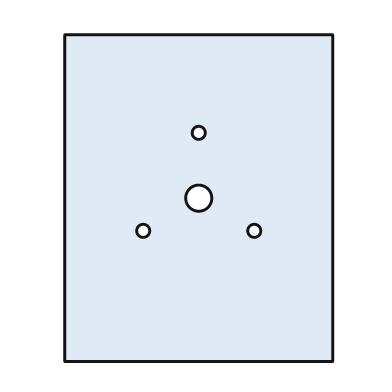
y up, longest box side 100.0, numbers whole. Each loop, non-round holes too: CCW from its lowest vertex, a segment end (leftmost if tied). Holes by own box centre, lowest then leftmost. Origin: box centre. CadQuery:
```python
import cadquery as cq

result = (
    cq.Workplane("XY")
    .moveTo(-41.0, -50.0)
    .lineTo(41.0, -50.0)
    .lineTo(41.0, 50.0)
    .lineTo(-41.0, 50.0)
    .close()
    .moveTo(-17.0, -10.0)
    .circle(2.0)
    .moveTo(17.0, -10.0)
    .circle(2.0)
    .moveTo(0.0, 0.0)
    .circle(4.0)
    .moveTo(0.0, 20.0)
    .circle(2.0)
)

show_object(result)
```